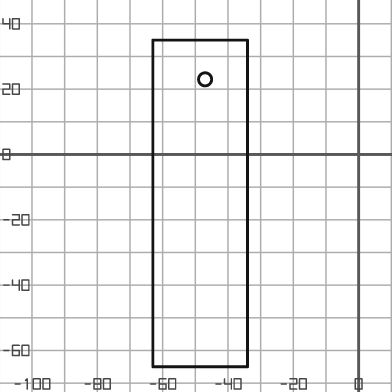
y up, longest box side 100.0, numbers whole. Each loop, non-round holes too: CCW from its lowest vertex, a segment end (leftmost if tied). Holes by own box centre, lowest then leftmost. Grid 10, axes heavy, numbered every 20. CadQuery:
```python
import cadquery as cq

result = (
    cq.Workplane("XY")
    .moveTo(-63.0, -65.0)
    .lineTo(-34.0, -65.0)
    .lineTo(-34.0, 35.0)
    .lineTo(-63.0, 35.0)
    .close()
    .moveTo(-47.0, 23.0)
    .circle(2.0)
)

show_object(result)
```